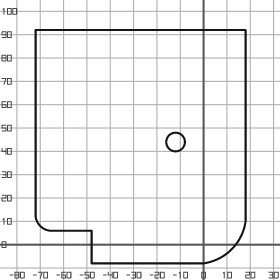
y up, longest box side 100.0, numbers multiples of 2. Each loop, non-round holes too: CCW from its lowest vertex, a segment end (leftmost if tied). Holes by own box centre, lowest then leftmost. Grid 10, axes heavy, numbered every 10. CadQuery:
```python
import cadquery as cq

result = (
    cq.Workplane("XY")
    .moveTo(-48.0, -8.0)
    .lineTo(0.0, -8.0)
    .threePointArc((12.0, -2.0), (18.0, 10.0))
    .lineTo(18.0, 92.0)
    .lineTo(-72.0, 92.0)
    .lineTo(-72.0, 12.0)
    .threePointArc((-70.0, 8.0), (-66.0, 6.0))
    .lineTo(-48.0, 6.0)
    .close()
    .moveTo(-12.0, 44.0)
    .circle(4.0)
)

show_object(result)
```